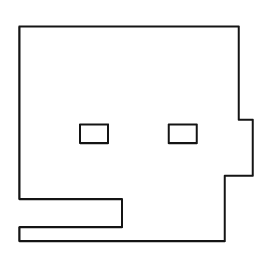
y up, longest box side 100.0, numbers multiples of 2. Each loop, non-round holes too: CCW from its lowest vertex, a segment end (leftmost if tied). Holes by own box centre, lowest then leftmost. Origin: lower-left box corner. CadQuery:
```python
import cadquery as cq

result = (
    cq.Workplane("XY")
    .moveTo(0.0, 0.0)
    .lineTo(88.0, 0.0)
    .lineTo(88.0, 28.0)
    .lineTo(100.0, 28.0)
    .lineTo(100.0, 52.0)
    .lineTo(94.0, 52.0)
    .lineTo(94.0, 92.0)
    .lineTo(0.0, 92.0)
    .lineTo(0.0, 18.0)
    .lineTo(44.0, 18.0)
    .lineTo(44.0, 6.0)
    .lineTo(0.0, 6.0)
    .close()
    .moveTo(26.0, 42.0)
    .lineTo(38.0, 42.0)
    .lineTo(38.0, 50.0)
    .lineTo(26.0, 50.0)
    .close()
    .moveTo(64.0, 42.0)
    .lineTo(76.0, 42.0)
    .lineTo(76.0, 50.0)
    .lineTo(64.0, 50.0)
    .close()
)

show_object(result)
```